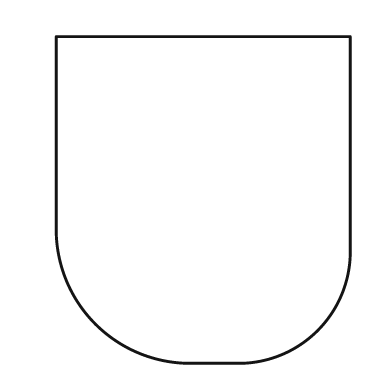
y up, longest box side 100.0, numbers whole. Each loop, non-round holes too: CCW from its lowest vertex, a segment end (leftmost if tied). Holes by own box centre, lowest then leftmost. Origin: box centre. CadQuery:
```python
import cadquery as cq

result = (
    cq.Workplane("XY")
    .moveTo(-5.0, -50.0)
    .lineTo(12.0, -50.0)
    .threePointArc((35.0, -40.0), (45.0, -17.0))
    .lineTo(45.0, 50.0)
    .lineTo(-45.0, 50.0)
    .lineTo(-45.0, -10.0)
    .threePointArc((-33.0, -38.0), (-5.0, -50.0))
    .close()
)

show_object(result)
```